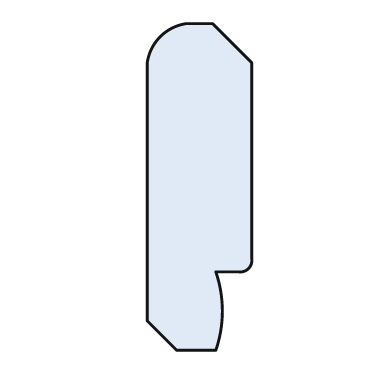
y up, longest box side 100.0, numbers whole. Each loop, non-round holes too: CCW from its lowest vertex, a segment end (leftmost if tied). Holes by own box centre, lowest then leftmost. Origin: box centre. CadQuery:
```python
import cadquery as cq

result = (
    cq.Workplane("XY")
    .moveTo(-7.0, -50.0)
    .lineTo(5.0, -50.0)
    .threePointArc((7.0, -38.0), (5.0, -26.0))
    .lineTo(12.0, -26.0)
    .threePointArc((15.0, -25.0), (16.0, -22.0))
    .lineTo(16.0, 38.0)
    .lineTo(4.0, 50.0)
    .lineTo(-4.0, 50.0)
    .threePointArc((-12.0, 46.0), (-16.0, 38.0))
    .lineTo(-16.0, -41.0)
    .close()
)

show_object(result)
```